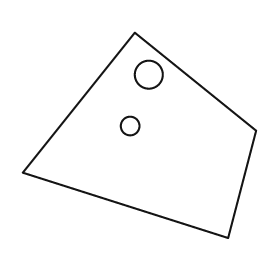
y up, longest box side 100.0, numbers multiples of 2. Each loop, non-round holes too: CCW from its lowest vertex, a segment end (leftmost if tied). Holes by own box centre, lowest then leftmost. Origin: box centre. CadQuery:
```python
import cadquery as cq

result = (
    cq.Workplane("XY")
    .moveTo(38.0, -44.0)
    .lineTo(50.0, 2.0)
    .lineTo(-2.0, 44.0)
    .lineTo(-50.0, -16.0)
    .close()
    .moveTo(-4.0, 4.0)
    .circle(4.0)
    .moveTo(4.0, 26.0)
    .circle(6.0)
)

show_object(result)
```